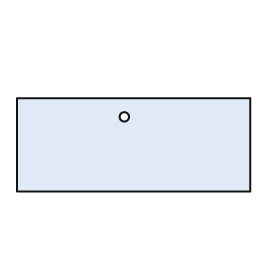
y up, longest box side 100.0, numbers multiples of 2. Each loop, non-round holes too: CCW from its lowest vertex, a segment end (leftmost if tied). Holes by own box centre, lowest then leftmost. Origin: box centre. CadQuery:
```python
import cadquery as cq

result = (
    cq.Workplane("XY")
    .moveTo(-50.0, -20.0)
    .lineTo(50.0, -20.0)
    .lineTo(50.0, 20.0)
    .lineTo(-50.0, 20.0)
    .close()
    .moveTo(-4.0, 12.0)
    .circle(2.0)
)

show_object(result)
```